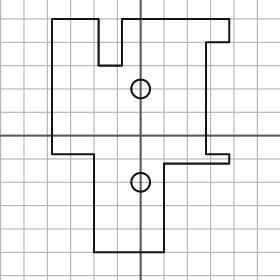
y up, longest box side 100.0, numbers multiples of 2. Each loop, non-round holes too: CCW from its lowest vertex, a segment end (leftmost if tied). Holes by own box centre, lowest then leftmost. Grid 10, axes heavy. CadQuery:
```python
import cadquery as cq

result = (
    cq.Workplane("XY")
    .moveTo(-20.0, -50.0)
    .lineTo(10.0, -50.0)
    .lineTo(10.0, -12.0)
    .lineTo(38.0, -12.0)
    .lineTo(38.0, -8.0)
    .lineTo(28.0, -8.0)
    .lineTo(28.0, 40.0)
    .lineTo(38.0, 40.0)
    .lineTo(38.0, 50.0)
    .lineTo(-8.0, 50.0)
    .lineTo(-8.0, 30.0)
    .lineTo(-18.0, 30.0)
    .lineTo(-18.0, 50.0)
    .lineTo(-38.0, 50.0)
    .lineTo(-38.0, -8.0)
    .lineTo(-20.0, -8.0)
    .close()
    .moveTo(0.0, -20.0)
    .circle(4.0)
    .moveTo(0.0, 20.0)
    .circle(4.0)
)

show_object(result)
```